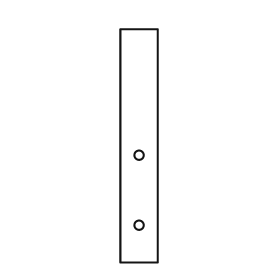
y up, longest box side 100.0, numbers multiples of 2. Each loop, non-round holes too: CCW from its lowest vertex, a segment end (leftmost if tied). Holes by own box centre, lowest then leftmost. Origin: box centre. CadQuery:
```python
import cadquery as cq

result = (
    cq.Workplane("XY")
    .moveTo(-8.0, -50.0)
    .lineTo(8.0, -50.0)
    .lineTo(8.0, 50.0)
    .lineTo(-8.0, 50.0)
    .close()
    .moveTo(0.0, -34.0)
    .circle(2.0)
    .moveTo(0.0, -4.0)
    .circle(2.0)
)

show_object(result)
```